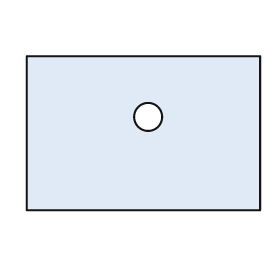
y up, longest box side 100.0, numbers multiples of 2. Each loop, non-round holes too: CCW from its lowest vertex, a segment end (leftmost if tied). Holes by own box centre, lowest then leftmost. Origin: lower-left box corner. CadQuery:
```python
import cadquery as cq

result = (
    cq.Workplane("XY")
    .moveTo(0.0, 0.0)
    .lineTo(100.0, 0.0)
    .lineTo(100.0, 66.0)
    .lineTo(0.0, 66.0)
    .close()
    .moveTo(52.0, 40.0)
    .circle(6.0)
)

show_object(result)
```